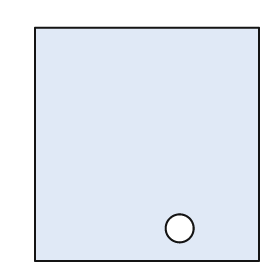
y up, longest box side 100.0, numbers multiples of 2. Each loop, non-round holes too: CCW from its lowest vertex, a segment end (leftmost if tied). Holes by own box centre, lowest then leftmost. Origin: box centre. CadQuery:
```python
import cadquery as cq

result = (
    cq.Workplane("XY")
    .moveTo(-48.0, -50.0)
    .lineTo(48.0, -50.0)
    .lineTo(48.0, 50.0)
    .lineTo(-48.0, 50.0)
    .close()
    .moveTo(14.0, -36.0)
    .circle(6.0)
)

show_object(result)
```